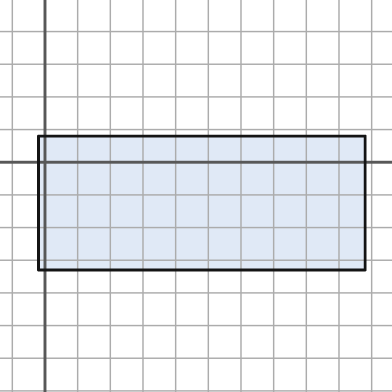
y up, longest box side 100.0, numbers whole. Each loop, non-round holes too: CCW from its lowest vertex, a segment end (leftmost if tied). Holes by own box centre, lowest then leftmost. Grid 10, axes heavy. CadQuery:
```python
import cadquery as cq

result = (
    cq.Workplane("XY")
    .moveTo(-2.0, -33.0)
    .lineTo(98.0, -33.0)
    .lineTo(98.0, 8.0)
    .lineTo(-2.0, 8.0)
    .close()
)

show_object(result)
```